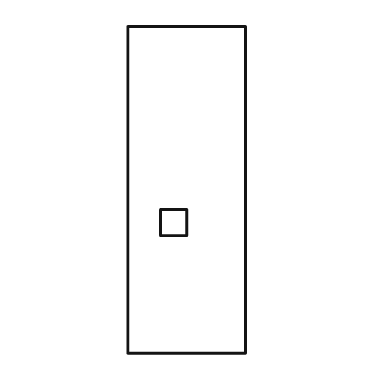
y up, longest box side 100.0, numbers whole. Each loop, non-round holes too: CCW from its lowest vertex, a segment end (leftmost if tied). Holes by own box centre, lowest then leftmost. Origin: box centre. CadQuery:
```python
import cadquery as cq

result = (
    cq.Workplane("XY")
    .moveTo(-18.0, -50.0)
    .lineTo(18.0, -50.0)
    .lineTo(18.0, 50.0)
    .lineTo(-18.0, 50.0)
    .close()
    .moveTo(-8.0, -14.0)
    .lineTo(0.0, -14.0)
    .lineTo(0.0, -6.0)
    .lineTo(-8.0, -6.0)
    .close()
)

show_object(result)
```